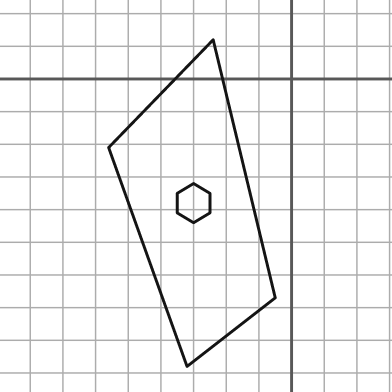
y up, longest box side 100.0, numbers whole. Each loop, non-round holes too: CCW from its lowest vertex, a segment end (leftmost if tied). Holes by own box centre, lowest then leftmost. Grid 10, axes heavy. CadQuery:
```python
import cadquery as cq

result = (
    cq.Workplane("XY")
    .moveTo(-32.0, -88.0)
    .lineTo(-5.0, -67.0)
    .lineTo(-24.0, 12.0)
    .lineTo(-56.0, -21.0)
    .close()
    .moveTo(-30.0, -44.0)
    .lineTo(-25.0, -41.0)
    .lineTo(-25.0, -35.0)
    .lineTo(-30.0, -32.0)
    .lineTo(-35.0, -35.0)
    .lineTo(-35.0, -41.0)
    .close()
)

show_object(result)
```